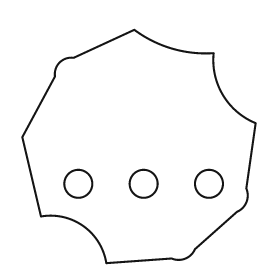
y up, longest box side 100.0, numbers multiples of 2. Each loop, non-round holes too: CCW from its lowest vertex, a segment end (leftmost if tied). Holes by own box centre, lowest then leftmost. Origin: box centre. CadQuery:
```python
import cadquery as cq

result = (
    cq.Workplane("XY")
    .moveTo(-14.0, -50.0)
    .lineTo(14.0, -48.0)
    .threePointArc((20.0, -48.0), (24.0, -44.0))
    .lineTo(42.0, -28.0)
    .threePointArc((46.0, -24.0), (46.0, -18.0))
    .lineTo(50.0, 10.0)
    .threePointArc((36.0, 22.0), (32.0, 40.0))
    .threePointArc((14.0, 42.0), (-2.0, 50.0))
    .lineTo(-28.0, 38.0)
    .threePointArc((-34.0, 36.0), (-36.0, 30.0))
    .lineTo(-50.0, 4.0)
    .lineTo(-42.0, -30.0)
    .threePointArc((-24.0, -34.0), (-14.0, -50.0))
    .close()
    .moveTo(-26.0, -16.0)
    .circle(6.0)
    .moveTo(2.0, -16.0)
    .circle(6.0)
    .moveTo(30.0, -16.0)
    .circle(6.0)
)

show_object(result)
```